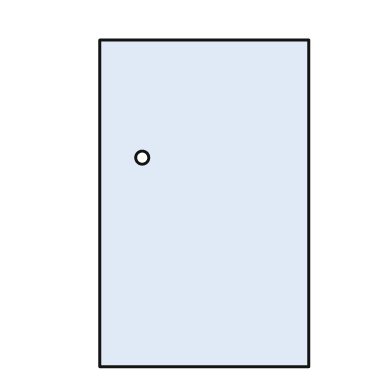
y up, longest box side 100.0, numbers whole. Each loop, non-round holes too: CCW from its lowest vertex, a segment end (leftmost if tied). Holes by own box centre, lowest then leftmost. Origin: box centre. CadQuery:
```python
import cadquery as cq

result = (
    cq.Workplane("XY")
    .moveTo(-32.0, -50.0)
    .lineTo(32.0, -50.0)
    .lineTo(32.0, 50.0)
    .lineTo(-32.0, 50.0)
    .close()
    .moveTo(-19.0, 14.0)
    .circle(2.0)
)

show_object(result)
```